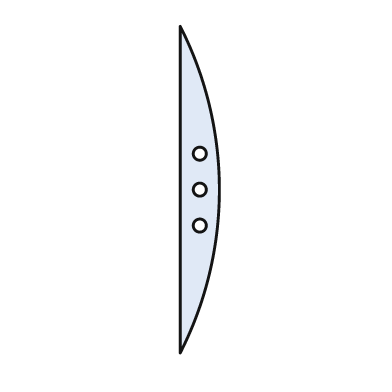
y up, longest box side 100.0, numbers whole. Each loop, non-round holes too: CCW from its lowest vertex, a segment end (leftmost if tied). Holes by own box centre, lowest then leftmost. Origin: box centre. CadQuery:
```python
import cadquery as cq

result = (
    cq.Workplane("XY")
    .moveTo(-6.0, -50.0)
    .threePointArc((6.0, 0.0), (-6.0, 50.0))
    .close()
    .moveTo(0.0, -11.0)
    .circle(2.0)
    .moveTo(0.0, 0.0)
    .circle(2.0)
    .moveTo(0.0, 11.0)
    .circle(2.0)
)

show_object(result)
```